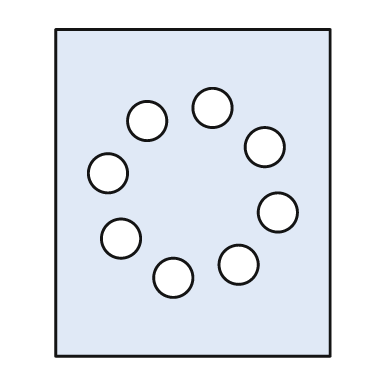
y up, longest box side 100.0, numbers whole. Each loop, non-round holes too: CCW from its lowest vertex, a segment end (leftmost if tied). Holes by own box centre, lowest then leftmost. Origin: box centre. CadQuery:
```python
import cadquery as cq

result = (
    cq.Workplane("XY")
    .moveTo(-42.0, -50.0)
    .lineTo(42.0, -50.0)
    .lineTo(42.0, 50.0)
    .lineTo(-42.0, 50.0)
    .close()
    .moveTo(-6.0, -26.0)
    .circle(6.0)
    .moveTo(14.0, -22.0)
    .circle(6.0)
    .moveTo(-22.0, -14.0)
    .circle(6.0)
    .moveTo(26.0, -6.0)
    .circle(6.0)
    .moveTo(-26.0, 6.0)
    .circle(6.0)
    .moveTo(22.0, 14.0)
    .circle(6.0)
    .moveTo(-14.0, 22.0)
    .circle(6.0)
    .moveTo(6.0, 26.0)
    .circle(6.0)
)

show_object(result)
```